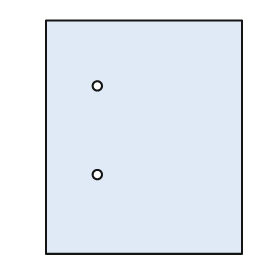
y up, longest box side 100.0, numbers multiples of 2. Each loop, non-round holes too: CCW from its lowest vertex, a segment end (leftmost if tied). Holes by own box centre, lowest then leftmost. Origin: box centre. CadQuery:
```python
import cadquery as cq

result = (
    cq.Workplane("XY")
    .moveTo(-42.0, -50.0)
    .lineTo(42.0, -50.0)
    .lineTo(42.0, 50.0)
    .lineTo(-42.0, 50.0)
    .close()
    .moveTo(-20.0, -16.0)
    .circle(2.0)
    .moveTo(-20.0, 22.0)
    .circle(2.0)
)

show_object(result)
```